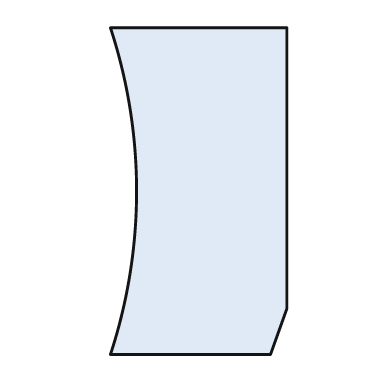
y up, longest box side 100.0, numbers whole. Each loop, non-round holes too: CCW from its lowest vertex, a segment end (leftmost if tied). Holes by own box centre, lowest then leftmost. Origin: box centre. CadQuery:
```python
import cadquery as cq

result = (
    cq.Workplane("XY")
    .moveTo(-27.0, -50.0)
    .lineTo(22.0, -50.0)
    .lineTo(27.0, -36.0)
    .lineTo(27.0, 50.0)
    .lineTo(-27.0, 50.0)
    .threePointArc((-19.0, 0.0), (-27.0, -50.0))
    .close()
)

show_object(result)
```